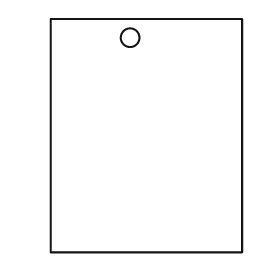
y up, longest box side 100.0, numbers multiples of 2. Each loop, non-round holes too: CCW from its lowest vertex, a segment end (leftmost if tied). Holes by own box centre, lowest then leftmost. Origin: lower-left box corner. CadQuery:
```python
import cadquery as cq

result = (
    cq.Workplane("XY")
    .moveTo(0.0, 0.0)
    .lineTo(82.0, 0.0)
    .lineTo(82.0, 100.0)
    .lineTo(0.0, 100.0)
    .close()
    .moveTo(34.0, 92.0)
    .circle(4.0)
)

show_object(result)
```